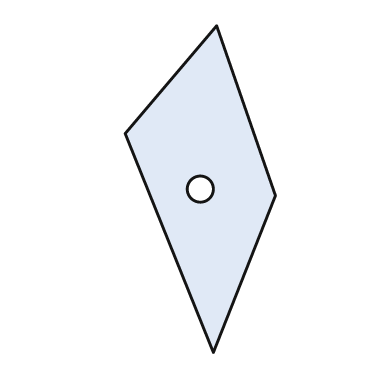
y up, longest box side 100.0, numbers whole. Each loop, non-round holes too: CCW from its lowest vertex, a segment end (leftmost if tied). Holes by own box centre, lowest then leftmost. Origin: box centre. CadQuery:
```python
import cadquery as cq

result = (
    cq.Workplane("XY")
    .moveTo(4.0, -50.0)
    .lineTo(23.0, -2.0)
    .lineTo(5.0, 50.0)
    .lineTo(-23.0, 17.0)
    .close()
    .moveTo(0.0, 0.0)
    .circle(4.0)
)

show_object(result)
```